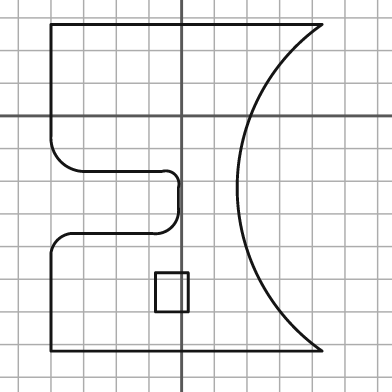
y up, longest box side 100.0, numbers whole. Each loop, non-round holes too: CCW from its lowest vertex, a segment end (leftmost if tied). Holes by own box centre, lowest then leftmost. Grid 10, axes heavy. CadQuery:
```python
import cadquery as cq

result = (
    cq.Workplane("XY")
    .moveTo(-40.0, -72.0)
    .lineTo(43.0, -72.0)
    .threePointArc((17.0, -22.0), (43.0, 28.0))
    .lineTo(-40.0, 28.0)
    .lineTo(-40.0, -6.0)
    .threePointArc((-37.0, -14.0), (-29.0, -17.0))
    .lineTo(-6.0, -17.0)
    .threePointArc((-2.0, -18.0), (-1.0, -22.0))
    .lineTo(-1.0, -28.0)
    .threePointArc((-3.0, -34.0), (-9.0, -36.0))
    .lineTo(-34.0, -36.0)
    .threePointArc((-38.0, -38.0), (-40.0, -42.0))
    .close()
    .moveTo(-8.0, -60.0)
    .lineTo(2.0, -60.0)
    .lineTo(2.0, -48.0)
    .lineTo(-8.0, -48.0)
    .close()
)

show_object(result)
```